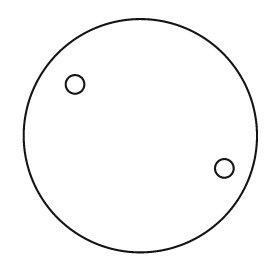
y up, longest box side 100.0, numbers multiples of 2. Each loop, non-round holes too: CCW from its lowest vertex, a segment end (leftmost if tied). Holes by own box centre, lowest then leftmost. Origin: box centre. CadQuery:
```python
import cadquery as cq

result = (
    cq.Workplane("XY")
    .moveTo(0.0, 0.0)
    .circle(50.0)
    .moveTo(36.0, -14.0)
    .circle(4.0)
    .moveTo(-28.0, 22.0)
    .circle(4.0)
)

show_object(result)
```